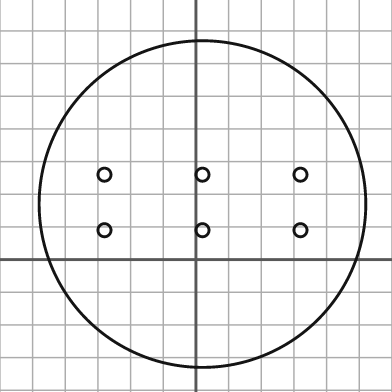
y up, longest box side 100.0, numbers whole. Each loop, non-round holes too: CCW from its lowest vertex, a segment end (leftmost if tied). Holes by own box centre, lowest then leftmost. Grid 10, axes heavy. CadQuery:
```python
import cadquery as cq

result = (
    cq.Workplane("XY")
    .moveTo(2.0, 17.0)
    .circle(50.0)
    .moveTo(-28.0, 9.0)
    .circle(2.0)
    .moveTo(2.0, 9.0)
    .circle(2.0)
    .moveTo(32.0, 9.0)
    .circle(2.0)
    .moveTo(-28.0, 26.0)
    .circle(2.0)
    .moveTo(2.0, 26.0)
    .circle(2.0)
    .moveTo(32.0, 26.0)
    .circle(2.0)
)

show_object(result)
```